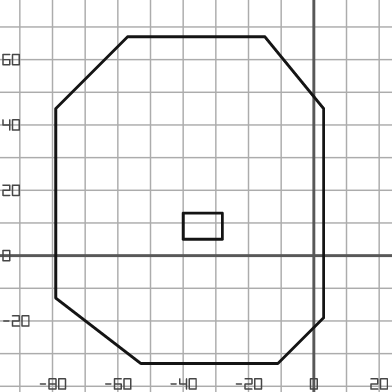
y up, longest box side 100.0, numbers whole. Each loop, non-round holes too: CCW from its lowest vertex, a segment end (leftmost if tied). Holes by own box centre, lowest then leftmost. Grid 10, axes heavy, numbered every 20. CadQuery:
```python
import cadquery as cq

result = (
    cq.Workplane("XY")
    .moveTo(-53.0, -33.0)
    .lineTo(-11.0, -33.0)
    .lineTo(3.0, -19.0)
    .lineTo(3.0, 45.0)
    .lineTo(-15.0, 67.0)
    .lineTo(-57.0, 67.0)
    .lineTo(-79.0, 45.0)
    .lineTo(-79.0, -13.0)
    .close()
    .moveTo(-40.0, 5.0)
    .lineTo(-28.0, 5.0)
    .lineTo(-28.0, 13.0)
    .lineTo(-40.0, 13.0)
    .close()
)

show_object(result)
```